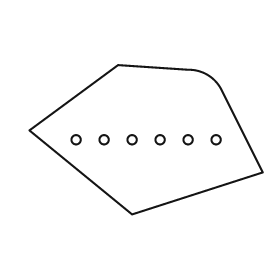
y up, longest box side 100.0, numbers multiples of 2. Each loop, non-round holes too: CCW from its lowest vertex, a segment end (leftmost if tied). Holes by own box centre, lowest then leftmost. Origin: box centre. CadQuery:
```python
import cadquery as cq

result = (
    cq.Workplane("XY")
    .moveTo(-6.0, -32.0)
    .lineTo(50.0, -14.0)
    .lineTo(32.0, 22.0)
    .threePointArc((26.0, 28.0), (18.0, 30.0))
    .lineTo(-12.0, 32.0)
    .lineTo(-50.0, 4.0)
    .close()
    .moveTo(-30.0, 0.0)
    .circle(2.0)
    .moveTo(-18.0, 0.0)
    .circle(2.0)
    .moveTo(-6.0, 0.0)
    .circle(2.0)
    .moveTo(6.0, 0.0)
    .circle(2.0)
    .moveTo(18.0, 0.0)
    .circle(2.0)
    .moveTo(30.0, 0.0)
    .circle(2.0)
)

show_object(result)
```